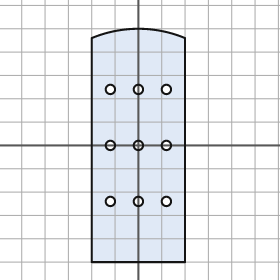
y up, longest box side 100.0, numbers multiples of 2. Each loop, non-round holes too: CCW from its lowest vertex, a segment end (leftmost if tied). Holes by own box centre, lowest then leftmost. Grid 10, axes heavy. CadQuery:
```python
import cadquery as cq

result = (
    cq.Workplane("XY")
    .moveTo(-20.0, -50.0)
    .lineTo(20.0, -50.0)
    .lineTo(20.0, 46.0)
    .threePointArc((0.0, 50.0), (-20.0, 46.0))
    .close()
    .moveTo(-12.0, -24.0)
    .circle(2.0)
    .moveTo(0.0, -24.0)
    .circle(2.0)
    .moveTo(12.0, -24.0)
    .circle(2.0)
    .moveTo(-12.0, 0.0)
    .circle(2.0)
    .moveTo(0.0, 0.0)
    .circle(2.0)
    .moveTo(12.0, 0.0)
    .circle(2.0)
    .moveTo(-12.0, 24.0)
    .circle(2.0)
    .moveTo(0.0, 24.0)
    .circle(2.0)
    .moveTo(12.0, 24.0)
    .circle(2.0)
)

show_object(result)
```